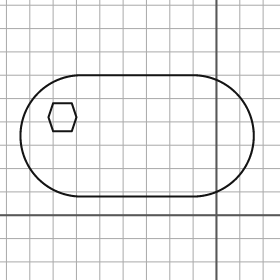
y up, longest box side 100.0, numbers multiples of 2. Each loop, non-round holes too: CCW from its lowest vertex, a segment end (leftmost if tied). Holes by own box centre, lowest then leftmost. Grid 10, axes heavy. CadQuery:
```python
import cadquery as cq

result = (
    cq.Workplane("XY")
    .moveTo(-58.0, 8.0)
    .lineTo(-10.0, 8.0)
    .threePointArc((16.0, 34.0), (-10.0, 60.0))
    .lineTo(-58.0, 60.0)
    .threePointArc((-84.0, 34.0), (-58.0, 8.0))
    .close()
    .moveTo(-70.0, 36.0)
    .lineTo(-62.0, 36.0)
    .lineTo(-60.0, 42.0)
    .lineTo(-62.0, 48.0)
    .lineTo(-70.0, 48.0)
    .lineTo(-72.0, 42.0)
    .close()
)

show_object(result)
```